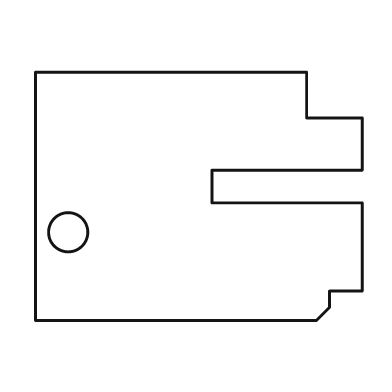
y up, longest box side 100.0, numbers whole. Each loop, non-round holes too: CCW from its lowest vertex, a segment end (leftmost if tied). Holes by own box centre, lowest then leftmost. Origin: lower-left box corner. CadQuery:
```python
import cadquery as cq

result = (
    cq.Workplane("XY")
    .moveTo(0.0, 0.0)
    .lineTo(86.0, 0.0)
    .lineTo(90.0, 4.0)
    .lineTo(90.0, 9.0)
    .lineTo(100.0, 9.0)
    .lineTo(100.0, 36.0)
    .lineTo(54.0, 36.0)
    .lineTo(54.0, 46.0)
    .lineTo(100.0, 46.0)
    .lineTo(100.0, 62.0)
    .lineTo(83.0, 62.0)
    .lineTo(83.0, 76.0)
    .lineTo(0.0, 76.0)
    .close()
    .moveTo(10.0, 27.0)
    .circle(6.0)
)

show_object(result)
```